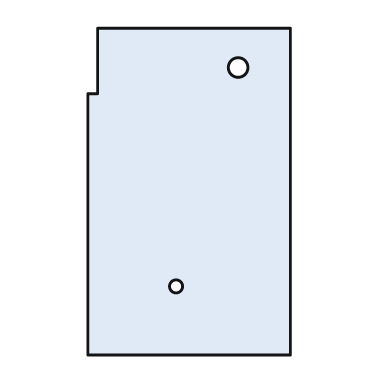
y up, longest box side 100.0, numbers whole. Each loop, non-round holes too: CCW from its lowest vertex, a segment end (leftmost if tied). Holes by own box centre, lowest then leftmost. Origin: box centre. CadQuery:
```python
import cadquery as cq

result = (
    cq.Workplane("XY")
    .moveTo(-31.0, -50.0)
    .lineTo(31.0, -50.0)
    .lineTo(31.0, 50.0)
    .lineTo(-28.0, 50.0)
    .lineTo(-28.0, 30.0)
    .lineTo(-31.0, 30.0)
    .close()
    .moveTo(-4.0, -29.0)
    .circle(2.0)
    .moveTo(15.0, 38.0)
    .circle(3.0)
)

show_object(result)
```